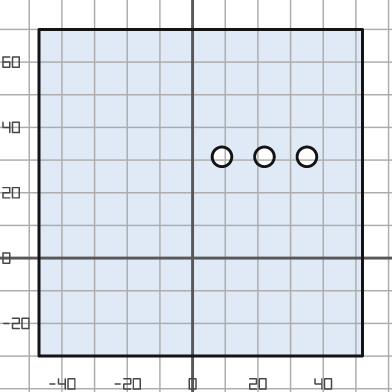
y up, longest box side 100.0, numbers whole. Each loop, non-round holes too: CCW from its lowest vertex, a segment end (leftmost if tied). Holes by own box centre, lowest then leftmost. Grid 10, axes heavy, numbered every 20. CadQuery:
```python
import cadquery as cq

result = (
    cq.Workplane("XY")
    .moveTo(-47.0, -30.0)
    .lineTo(52.0, -30.0)
    .lineTo(52.0, 70.0)
    .lineTo(-47.0, 70.0)
    .close()
    .moveTo(9.0, 31.0)
    .circle(3.0)
    .moveTo(22.0, 31.0)
    .circle(3.0)
    .moveTo(35.0, 31.0)
    .circle(3.0)
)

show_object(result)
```